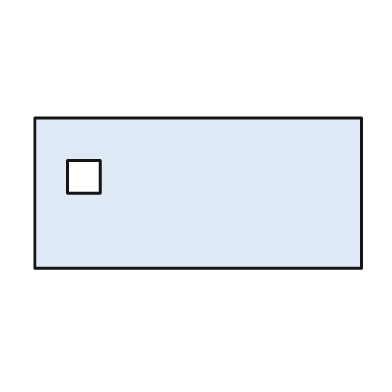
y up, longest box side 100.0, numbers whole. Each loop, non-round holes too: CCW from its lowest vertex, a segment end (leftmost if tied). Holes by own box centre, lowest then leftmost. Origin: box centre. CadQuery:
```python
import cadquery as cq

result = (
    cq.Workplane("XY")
    .moveTo(-50.0, -23.0)
    .lineTo(50.0, -23.0)
    .lineTo(50.0, 23.0)
    .lineTo(-50.0, 23.0)
    .close()
    .moveTo(-40.0, 0.0)
    .lineTo(-30.0, 0.0)
    .lineTo(-30.0, 10.0)
    .lineTo(-40.0, 10.0)
    .close()
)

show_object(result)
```